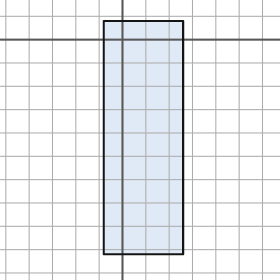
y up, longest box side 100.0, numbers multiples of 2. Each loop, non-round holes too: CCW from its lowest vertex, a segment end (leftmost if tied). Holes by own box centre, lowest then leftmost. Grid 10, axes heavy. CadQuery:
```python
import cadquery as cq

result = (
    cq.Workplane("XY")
    .moveTo(-8.0, -92.0)
    .lineTo(26.0, -92.0)
    .lineTo(26.0, 8.0)
    .lineTo(-8.0, 8.0)
    .close()
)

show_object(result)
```